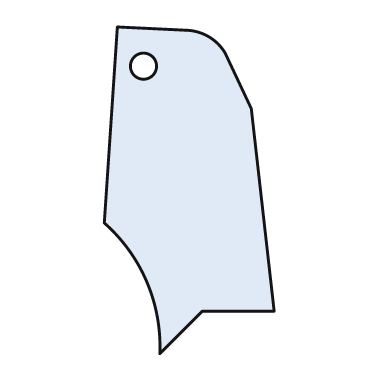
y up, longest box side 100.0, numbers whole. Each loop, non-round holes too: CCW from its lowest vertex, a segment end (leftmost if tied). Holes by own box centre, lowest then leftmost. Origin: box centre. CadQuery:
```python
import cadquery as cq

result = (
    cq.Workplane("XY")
    .moveTo(-9.0, -50.0)
    .lineTo(4.0, -37.0)
    .lineTo(26.0, -37.0)
    .lineTo(19.0, 25.0)
    .lineTo(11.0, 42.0)
    .threePointArc((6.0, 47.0), (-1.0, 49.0))
    .lineTo(-22.0, 50.0)
    .lineTo(-26.0, -10.0)
    .threePointArc((-13.0, -28.0), (-9.0, -50.0))
    .close()
    .moveTo(-14.0, 38.0)
    .circle(4.0)
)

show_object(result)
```